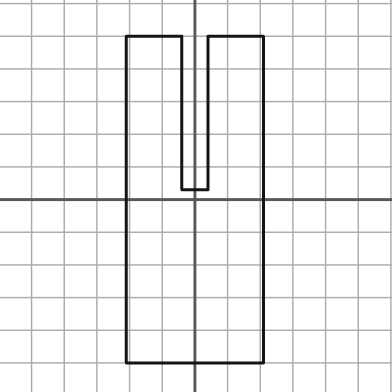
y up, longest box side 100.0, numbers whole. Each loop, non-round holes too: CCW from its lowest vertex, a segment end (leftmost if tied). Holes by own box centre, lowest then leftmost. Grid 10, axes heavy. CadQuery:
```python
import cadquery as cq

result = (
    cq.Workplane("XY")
    .moveTo(-21.0, -50.0)
    .lineTo(21.0, -50.0)
    .lineTo(21.0, 50.0)
    .lineTo(4.0, 50.0)
    .lineTo(4.0, 3.0)
    .lineTo(-4.0, 3.0)
    .lineTo(-4.0, 50.0)
    .lineTo(-21.0, 50.0)
    .close()
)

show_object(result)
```